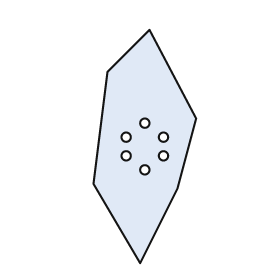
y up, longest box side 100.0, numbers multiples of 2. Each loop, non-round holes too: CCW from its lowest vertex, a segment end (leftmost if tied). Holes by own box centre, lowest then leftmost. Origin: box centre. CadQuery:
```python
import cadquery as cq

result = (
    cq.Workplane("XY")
    .moveTo(-2.0, -50.0)
    .lineTo(14.0, -18.0)
    .lineTo(22.0, 12.0)
    .lineTo(2.0, 50.0)
    .lineTo(-16.0, 32.0)
    .lineTo(-22.0, -16.0)
    .close()
    .moveTo(0.0, -10.0)
    .circle(2.0)
    .moveTo(-8.0, -4.0)
    .circle(2.0)
    .moveTo(8.0, -4.0)
    .circle(2.0)
    .moveTo(-8.0, 4.0)
    .circle(2.0)
    .moveTo(8.0, 4.0)
    .circle(2.0)
    .moveTo(0.0, 10.0)
    .circle(2.0)
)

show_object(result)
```